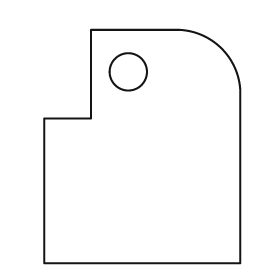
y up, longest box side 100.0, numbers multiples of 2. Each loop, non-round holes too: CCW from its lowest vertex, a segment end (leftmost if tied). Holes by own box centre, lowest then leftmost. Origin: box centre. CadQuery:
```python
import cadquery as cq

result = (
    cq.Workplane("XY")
    .moveTo(-42.0, -50.0)
    .lineTo(42.0, -50.0)
    .lineTo(42.0, 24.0)
    .threePointArc((34.0, 42.0), (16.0, 50.0))
    .lineTo(-22.0, 50.0)
    .lineTo(-22.0, 12.0)
    .lineTo(-42.0, 12.0)
    .close()
    .moveTo(-6.0, 32.0)
    .circle(8.0)
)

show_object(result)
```